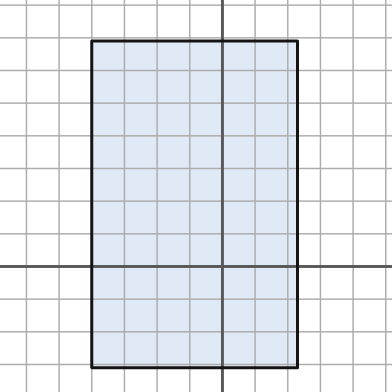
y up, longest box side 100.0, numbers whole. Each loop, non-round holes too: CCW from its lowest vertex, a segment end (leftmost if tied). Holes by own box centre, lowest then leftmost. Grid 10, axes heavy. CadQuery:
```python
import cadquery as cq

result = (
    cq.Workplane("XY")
    .moveTo(-40.0, -31.0)
    .lineTo(23.0, -31.0)
    .lineTo(23.0, 69.0)
    .lineTo(-40.0, 69.0)
    .close()
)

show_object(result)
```